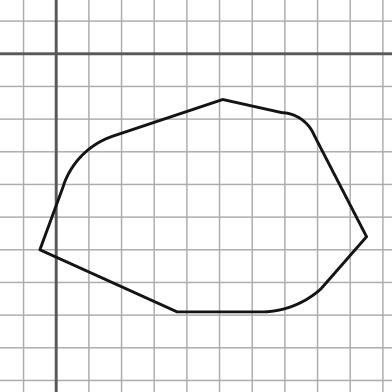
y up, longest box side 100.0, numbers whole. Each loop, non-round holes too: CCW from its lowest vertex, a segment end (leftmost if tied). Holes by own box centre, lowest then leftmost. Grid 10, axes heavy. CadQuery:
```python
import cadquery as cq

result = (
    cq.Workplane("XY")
    .moveTo(37.0, -79.0)
    .lineTo(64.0, -79.0)
    .threePointArc((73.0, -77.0), (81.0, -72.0))
    .lineTo(95.0, -56.0)
    .lineTo(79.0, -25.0)
    .threePointArc((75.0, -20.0), (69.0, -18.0))
    .lineTo(51.0, -14.0)
    .lineTo(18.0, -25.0)
    .threePointArc((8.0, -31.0), (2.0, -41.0))
    .lineTo(-5.0, -60.0)
    .close()
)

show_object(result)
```